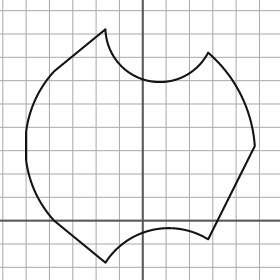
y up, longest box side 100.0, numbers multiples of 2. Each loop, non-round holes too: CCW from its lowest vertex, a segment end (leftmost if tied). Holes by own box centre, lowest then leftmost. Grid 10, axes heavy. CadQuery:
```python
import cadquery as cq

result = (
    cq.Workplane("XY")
    .moveTo(-16.0, -18.0)
    .threePointArc((4.0, -4.0), (28.0, -8.0))
    .lineTo(48.0, 32.0)
    .threePointArc((42.0, 54.0), (28.0, 72.0))
    .threePointArc((2.0, 60.0), (-16.0, 82.0))
    .lineTo(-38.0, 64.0)
    .threePointArc((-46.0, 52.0), (-50.0, 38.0))
    .lineTo(-50.0, 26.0)
    .threePointArc((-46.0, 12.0), (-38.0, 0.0))
    .close()
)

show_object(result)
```